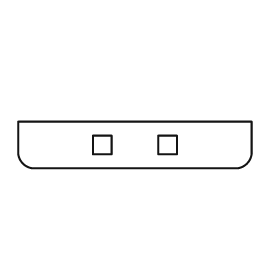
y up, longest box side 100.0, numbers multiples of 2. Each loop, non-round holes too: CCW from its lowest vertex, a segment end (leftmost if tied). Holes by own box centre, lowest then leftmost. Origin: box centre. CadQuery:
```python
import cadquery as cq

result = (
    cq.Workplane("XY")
    .moveTo(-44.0, -10.0)
    .lineTo(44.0, -10.0)
    .threePointArc((48.0, -8.0), (50.0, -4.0))
    .lineTo(50.0, 10.0)
    .lineTo(-50.0, 10.0)
    .lineTo(-50.0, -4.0)
    .threePointArc((-48.0, -8.0), (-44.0, -10.0))
    .close()
    .moveTo(-18.0, -4.0)
    .lineTo(-10.0, -4.0)
    .lineTo(-10.0, 4.0)
    .lineTo(-18.0, 4.0)
    .close()
    .moveTo(10.0, -4.0)
    .lineTo(18.0, -4.0)
    .lineTo(18.0, 4.0)
    .lineTo(10.0, 4.0)
    .close()
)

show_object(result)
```